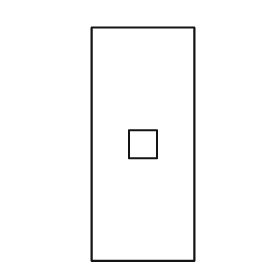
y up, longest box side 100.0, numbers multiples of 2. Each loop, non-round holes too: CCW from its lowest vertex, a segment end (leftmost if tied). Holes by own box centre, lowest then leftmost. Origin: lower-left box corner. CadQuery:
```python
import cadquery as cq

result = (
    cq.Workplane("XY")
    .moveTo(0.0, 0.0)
    .lineTo(44.0, 0.0)
    .lineTo(44.0, 100.0)
    .lineTo(0.0, 100.0)
    .close()
    .moveTo(16.0, 44.0)
    .lineTo(28.0, 44.0)
    .lineTo(28.0, 56.0)
    .lineTo(16.0, 56.0)
    .close()
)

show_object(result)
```